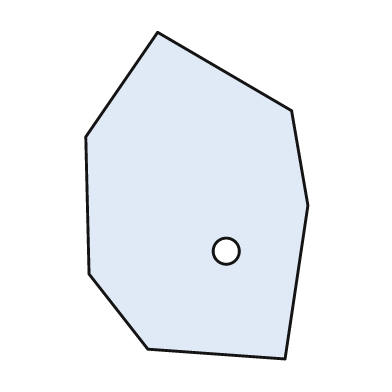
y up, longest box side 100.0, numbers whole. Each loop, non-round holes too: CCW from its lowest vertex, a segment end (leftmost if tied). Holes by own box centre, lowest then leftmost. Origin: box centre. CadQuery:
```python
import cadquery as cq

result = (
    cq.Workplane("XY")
    .moveTo(27.0, -50.0)
    .lineTo(34.0, -3.0)
    .lineTo(29.0, 26.0)
    .lineTo(-12.0, 50.0)
    .lineTo(-34.0, 18.0)
    .lineTo(-33.0, -24.0)
    .lineTo(-15.0, -47.0)
    .close()
    .moveTo(9.0, -17.0)
    .circle(4.0)
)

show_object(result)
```